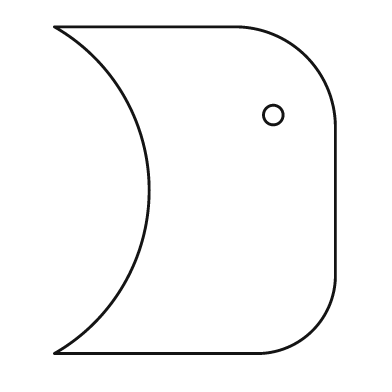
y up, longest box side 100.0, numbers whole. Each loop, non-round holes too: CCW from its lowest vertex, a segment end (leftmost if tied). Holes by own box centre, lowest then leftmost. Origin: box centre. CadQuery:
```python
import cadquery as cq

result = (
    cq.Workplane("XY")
    .moveTo(-43.0, -50.0)
    .lineTo(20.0, -50.0)
    .threePointArc((36.0, -43.0), (43.0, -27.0))
    .lineTo(43.0, 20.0)
    .threePointArc((34.0, 41.0), (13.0, 50.0))
    .lineTo(-43.0, 50.0)
    .threePointArc((-14.0, 0.0), (-43.0, -50.0))
    .close()
    .moveTo(24.0, 23.0)
    .circle(3.0)
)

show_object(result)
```